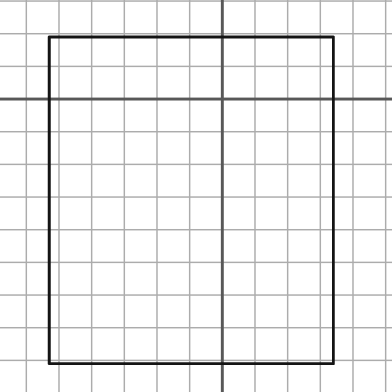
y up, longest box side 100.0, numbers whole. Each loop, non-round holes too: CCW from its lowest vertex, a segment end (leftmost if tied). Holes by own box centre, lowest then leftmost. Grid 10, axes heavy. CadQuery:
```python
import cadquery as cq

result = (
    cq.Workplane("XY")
    .moveTo(-53.0, -81.0)
    .lineTo(34.0, -81.0)
    .lineTo(34.0, 19.0)
    .lineTo(-53.0, 19.0)
    .close()
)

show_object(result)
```